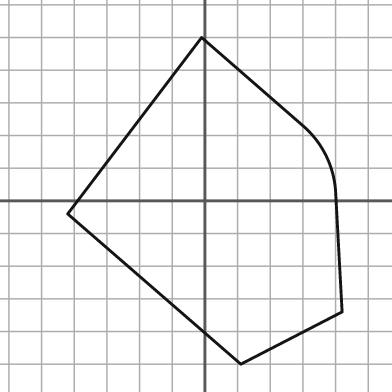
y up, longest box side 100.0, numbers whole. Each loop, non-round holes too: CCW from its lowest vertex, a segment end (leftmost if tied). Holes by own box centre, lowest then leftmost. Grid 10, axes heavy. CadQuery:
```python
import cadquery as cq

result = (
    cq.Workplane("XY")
    .moveTo(11.0, -50.0)
    .lineTo(42.0, -34.0)
    .lineTo(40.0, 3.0)
    .threePointArc((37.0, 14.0), (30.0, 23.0))
    .lineTo(-1.0, 50.0)
    .lineTo(-42.0, -4.0)
    .close()
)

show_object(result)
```